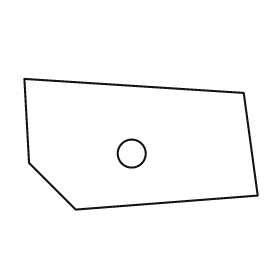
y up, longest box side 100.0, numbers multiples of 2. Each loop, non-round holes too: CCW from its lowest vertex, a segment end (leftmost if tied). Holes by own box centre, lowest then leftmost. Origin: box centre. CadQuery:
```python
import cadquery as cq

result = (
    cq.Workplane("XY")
    .moveTo(-28.0, -28.0)
    .lineTo(50.0, -22.0)
    .lineTo(44.0, 22.0)
    .lineTo(-50.0, 28.0)
    .lineTo(-48.0, -8.0)
    .close()
    .moveTo(-4.0, -4.0)
    .circle(6.0)
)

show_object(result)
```